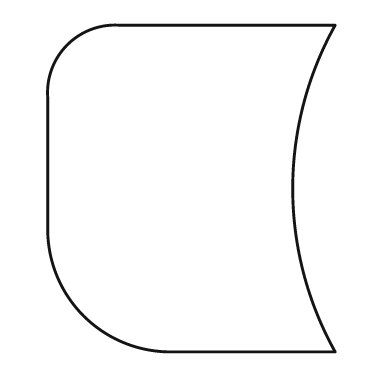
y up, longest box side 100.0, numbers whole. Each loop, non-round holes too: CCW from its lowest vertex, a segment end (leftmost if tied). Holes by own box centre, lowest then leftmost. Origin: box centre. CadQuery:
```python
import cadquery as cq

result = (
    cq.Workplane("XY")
    .moveTo(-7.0, -50.0)
    .lineTo(44.0, -50.0)
    .threePointArc((31.0, 0.0), (44.0, 50.0))
    .lineTo(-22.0, 50.0)
    .threePointArc((-38.0, 44.0), (-44.0, 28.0))
    .lineTo(-44.0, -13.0)
    .threePointArc((-33.0, -39.0), (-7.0, -50.0))
    .close()
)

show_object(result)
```